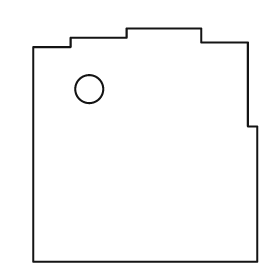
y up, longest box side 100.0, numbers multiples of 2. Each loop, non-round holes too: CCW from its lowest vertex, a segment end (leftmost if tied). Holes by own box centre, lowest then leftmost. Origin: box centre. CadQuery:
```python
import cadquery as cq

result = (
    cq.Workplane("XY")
    .moveTo(-48.0, -50.0)
    .lineTo(48.0, -50.0)
    .lineTo(48.0, 8.0)
    .lineTo(44.0, 8.0)
    .lineTo(44.0, 44.0)
    .lineTo(24.0, 44.0)
    .lineTo(24.0, 50.0)
    .lineTo(-8.0, 50.0)
    .lineTo(-8.0, 46.0)
    .lineTo(-32.0, 46.0)
    .lineTo(-32.0, 42.0)
    .lineTo(-48.0, 42.0)
    .close()
    .moveTo(-24.0, 24.0)
    .circle(6.0)
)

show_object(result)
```